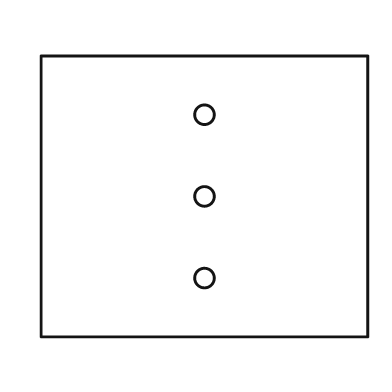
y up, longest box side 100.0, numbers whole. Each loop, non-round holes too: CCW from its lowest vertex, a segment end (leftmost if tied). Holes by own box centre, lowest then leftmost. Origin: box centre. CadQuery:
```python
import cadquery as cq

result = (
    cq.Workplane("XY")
    .moveTo(-50.0, -43.0)
    .lineTo(50.0, -43.0)
    .lineTo(50.0, 43.0)
    .lineTo(-50.0, 43.0)
    .close()
    .moveTo(0.0, -25.0)
    .circle(3.0)
    .moveTo(0.0, 0.0)
    .circle(3.0)
    .moveTo(0.0, 25.0)
    .circle(3.0)
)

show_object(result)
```